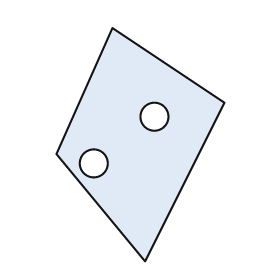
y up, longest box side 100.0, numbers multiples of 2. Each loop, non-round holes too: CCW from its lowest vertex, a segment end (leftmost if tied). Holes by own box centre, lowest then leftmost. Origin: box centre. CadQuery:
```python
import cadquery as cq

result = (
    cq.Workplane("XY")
    .moveTo(2.0, -50.0)
    .lineTo(36.0, 18.0)
    .lineTo(-12.0, 50.0)
    .lineTo(-36.0, -4.0)
    .close()
    .moveTo(-20.0, -8.0)
    .circle(6.0)
    .moveTo(6.0, 12.0)
    .circle(6.0)
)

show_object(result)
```